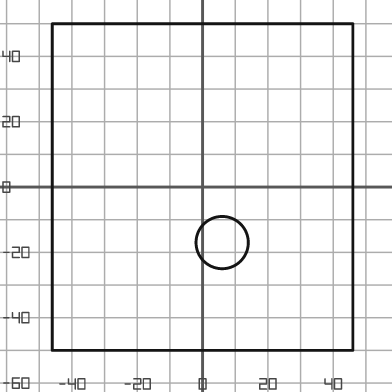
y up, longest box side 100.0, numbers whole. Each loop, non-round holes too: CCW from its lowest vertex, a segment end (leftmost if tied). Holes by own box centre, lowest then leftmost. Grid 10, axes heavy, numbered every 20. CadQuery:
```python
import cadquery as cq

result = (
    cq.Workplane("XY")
    .moveTo(-46.0, -50.0)
    .lineTo(46.0, -50.0)
    .lineTo(46.0, 50.0)
    .lineTo(-46.0, 50.0)
    .close()
    .moveTo(6.0, -17.0)
    .circle(8.0)
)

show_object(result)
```